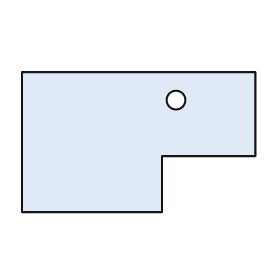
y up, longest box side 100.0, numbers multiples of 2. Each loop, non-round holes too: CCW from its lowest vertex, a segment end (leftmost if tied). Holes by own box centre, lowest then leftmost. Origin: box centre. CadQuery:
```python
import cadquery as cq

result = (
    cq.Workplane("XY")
    .moveTo(-50.0, -30.0)
    .lineTo(10.0, -30.0)
    .lineTo(10.0, -6.0)
    .lineTo(50.0, -6.0)
    .lineTo(50.0, 30.0)
    .lineTo(-50.0, 30.0)
    .close()
    .moveTo(16.0, 18.0)
    .circle(4.0)
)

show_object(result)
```